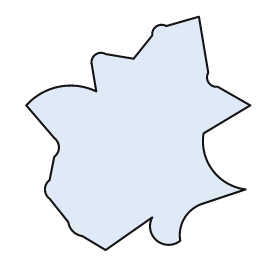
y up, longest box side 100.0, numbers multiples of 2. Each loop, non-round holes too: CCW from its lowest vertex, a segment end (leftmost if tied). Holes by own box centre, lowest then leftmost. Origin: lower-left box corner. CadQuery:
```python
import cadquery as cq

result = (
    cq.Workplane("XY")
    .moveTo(34.0, 0.0)
    .lineTo(54.0, 14.0)
    .threePointArc((56.0, 4.0), (66.0, 4.0))
    .threePointArc((68.0, 14.0), (76.0, 20.0))
    .lineTo(94.0, 26.0)
    .threePointArc((80.0, 34.0), (76.0, 50.0))
    .lineTo(96.0, 62.0)
    .lineTo(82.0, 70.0)
    .threePointArc((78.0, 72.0), (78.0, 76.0))
    .lineTo(74.0, 100.0)
    .lineTo(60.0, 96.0)
    .threePointArc((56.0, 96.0), (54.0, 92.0))
    .lineTo(46.0, 82.0)
    .lineTo(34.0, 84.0)
    .threePointArc((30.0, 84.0), (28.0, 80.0))
    .lineTo(30.0, 68.0)
    .threePointArc((14.0, 70.0), (0.0, 62.0))
    .lineTo(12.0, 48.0)
    .threePointArc((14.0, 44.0), (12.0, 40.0))
    .lineTo(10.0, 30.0)
    .threePointArc((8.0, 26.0), (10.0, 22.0))
    .lineTo(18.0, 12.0)
    .threePointArc((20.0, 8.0), (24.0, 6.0))
    .close()
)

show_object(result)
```